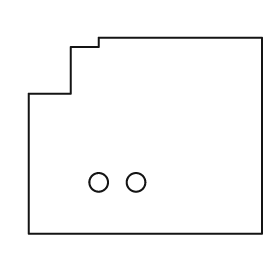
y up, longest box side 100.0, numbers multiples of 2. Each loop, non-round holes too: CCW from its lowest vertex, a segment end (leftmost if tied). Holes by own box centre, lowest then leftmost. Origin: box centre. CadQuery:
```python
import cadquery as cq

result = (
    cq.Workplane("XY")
    .moveTo(-50.0, -42.0)
    .lineTo(50.0, -42.0)
    .lineTo(50.0, 42.0)
    .lineTo(-20.0, 42.0)
    .lineTo(-20.0, 38.0)
    .lineTo(-32.0, 38.0)
    .lineTo(-32.0, 18.0)
    .lineTo(-50.0, 18.0)
    .close()
    .moveTo(-20.0, -20.0)
    .circle(4.0)
    .moveTo(-4.0, -20.0)
    .circle(4.0)
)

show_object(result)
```